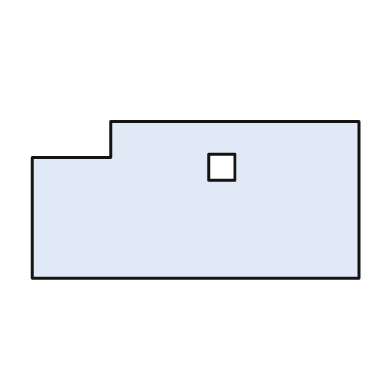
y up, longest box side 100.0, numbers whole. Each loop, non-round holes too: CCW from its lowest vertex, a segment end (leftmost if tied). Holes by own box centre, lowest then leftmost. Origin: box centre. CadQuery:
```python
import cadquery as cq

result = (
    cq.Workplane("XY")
    .moveTo(-50.0, -24.0)
    .lineTo(50.0, -24.0)
    .lineTo(50.0, 24.0)
    .lineTo(-26.0, 24.0)
    .lineTo(-26.0, 13.0)
    .lineTo(-50.0, 13.0)
    .close()
    .moveTo(4.0, 6.0)
    .lineTo(12.0, 6.0)
    .lineTo(12.0, 14.0)
    .lineTo(4.0, 14.0)
    .close()
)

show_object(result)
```